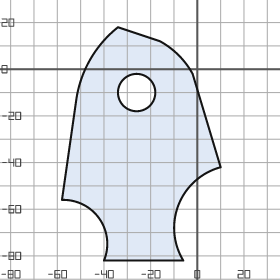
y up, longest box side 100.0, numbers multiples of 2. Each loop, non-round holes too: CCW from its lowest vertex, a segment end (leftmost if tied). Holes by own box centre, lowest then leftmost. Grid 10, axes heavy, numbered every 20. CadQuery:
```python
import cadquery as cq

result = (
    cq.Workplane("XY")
    .moveTo(-40.0, -82.0)
    .lineTo(-6.0, -82.0)
    .threePointArc((-8.0, -58.0), (10.0, -42.0))
    .lineTo(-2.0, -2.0)
    .threePointArc((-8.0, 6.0), (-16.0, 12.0))
    .lineTo(-34.0, 18.0)
    .threePointArc((-46.0, 4.0), (-52.0, -14.0))
    .lineTo(-58.0, -56.0)
    .threePointArc((-42.0, -64.0), (-40.0, -82.0))
    .close()
    .moveTo(-26.0, -10.0)
    .circle(8.0)
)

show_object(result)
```